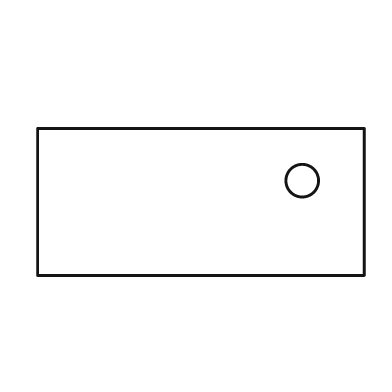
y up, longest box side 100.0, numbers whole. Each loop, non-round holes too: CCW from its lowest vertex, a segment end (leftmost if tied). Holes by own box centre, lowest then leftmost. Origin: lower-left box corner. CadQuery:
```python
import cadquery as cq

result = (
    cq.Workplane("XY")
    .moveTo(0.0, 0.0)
    .lineTo(100.0, 0.0)
    .lineTo(100.0, 45.0)
    .lineTo(0.0, 45.0)
    .close()
    .moveTo(81.0, 29.0)
    .circle(5.0)
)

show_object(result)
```